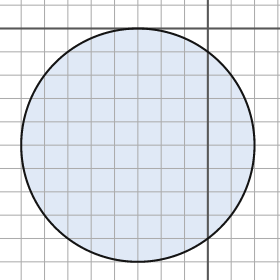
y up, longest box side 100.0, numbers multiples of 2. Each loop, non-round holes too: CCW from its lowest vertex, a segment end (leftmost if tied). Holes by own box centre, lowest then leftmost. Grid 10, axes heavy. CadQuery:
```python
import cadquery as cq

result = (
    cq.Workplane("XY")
    .moveTo(-30.0, -50.0)
    .circle(50.0)
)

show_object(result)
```